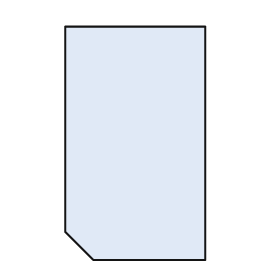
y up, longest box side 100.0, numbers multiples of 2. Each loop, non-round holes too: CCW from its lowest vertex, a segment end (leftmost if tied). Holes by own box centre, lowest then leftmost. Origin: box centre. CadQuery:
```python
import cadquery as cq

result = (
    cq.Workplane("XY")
    .moveTo(-18.0, -50.0)
    .lineTo(30.0, -50.0)
    .lineTo(30.0, 50.0)
    .lineTo(-30.0, 50.0)
    .lineTo(-30.0, -38.0)
    .close()
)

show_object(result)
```